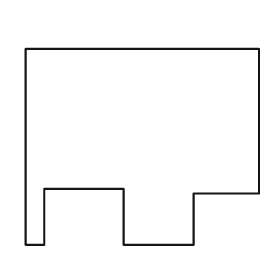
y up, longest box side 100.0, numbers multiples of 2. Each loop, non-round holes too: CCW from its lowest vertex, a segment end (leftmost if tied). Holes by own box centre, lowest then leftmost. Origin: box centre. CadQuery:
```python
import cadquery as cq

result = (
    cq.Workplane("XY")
    .moveTo(-50.0, -42.0)
    .lineTo(-42.0, -42.0)
    .lineTo(-42.0, -18.0)
    .lineTo(-8.0, -18.0)
    .lineTo(-8.0, -42.0)
    .lineTo(22.0, -42.0)
    .lineTo(22.0, -20.0)
    .lineTo(50.0, -20.0)
    .lineTo(50.0, 42.0)
    .lineTo(-50.0, 42.0)
    .close()
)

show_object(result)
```